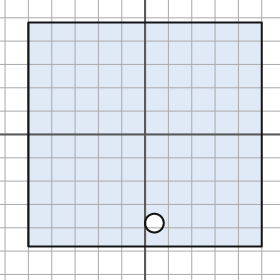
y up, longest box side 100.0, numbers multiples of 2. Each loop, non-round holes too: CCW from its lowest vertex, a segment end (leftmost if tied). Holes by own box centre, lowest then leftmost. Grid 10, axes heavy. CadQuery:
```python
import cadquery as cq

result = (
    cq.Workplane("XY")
    .moveTo(-50.0, -48.0)
    .lineTo(50.0, -48.0)
    .lineTo(50.0, 48.0)
    .lineTo(-50.0, 48.0)
    .close()
    .moveTo(4.0, -38.0)
    .circle(4.0)
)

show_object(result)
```